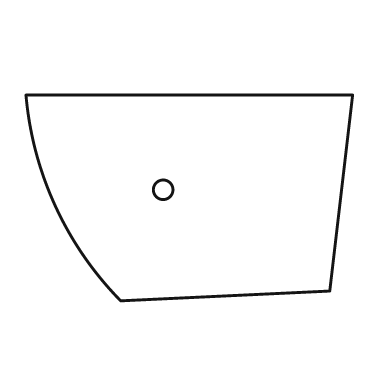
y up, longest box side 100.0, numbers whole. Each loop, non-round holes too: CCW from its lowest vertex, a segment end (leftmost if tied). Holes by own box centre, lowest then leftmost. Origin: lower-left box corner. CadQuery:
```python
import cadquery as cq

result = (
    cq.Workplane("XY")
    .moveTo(29.0, 0.0)
    .lineTo(93.0, 3.0)
    .lineTo(100.0, 63.0)
    .lineTo(0.0, 63.0)
    .threePointArc((9.0, 29.0), (29.0, 0.0))
    .close()
    .moveTo(42.0, 34.0)
    .circle(3.0)
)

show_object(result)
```